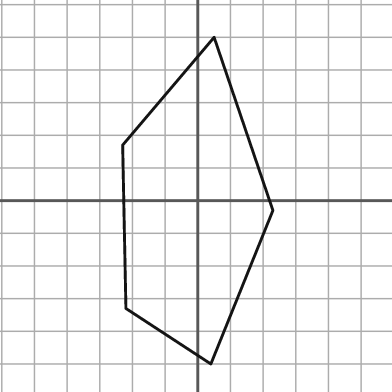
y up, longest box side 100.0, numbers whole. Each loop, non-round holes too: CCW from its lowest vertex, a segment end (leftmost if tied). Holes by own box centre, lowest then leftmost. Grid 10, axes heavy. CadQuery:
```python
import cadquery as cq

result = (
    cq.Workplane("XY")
    .moveTo(4.0, -50.0)
    .lineTo(23.0, -3.0)
    .lineTo(5.0, 50.0)
    .lineTo(-23.0, 17.0)
    .lineTo(-22.0, -33.0)
    .close()
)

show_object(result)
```